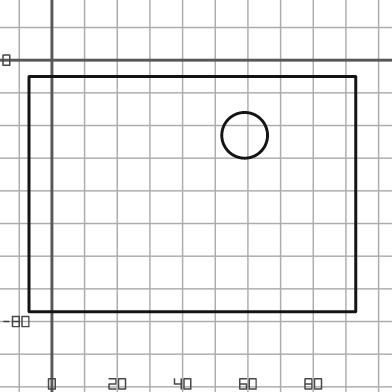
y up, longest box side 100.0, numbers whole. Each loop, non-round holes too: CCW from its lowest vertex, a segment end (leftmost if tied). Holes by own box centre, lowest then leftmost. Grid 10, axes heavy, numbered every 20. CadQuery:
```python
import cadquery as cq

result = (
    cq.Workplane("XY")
    .moveTo(-7.0, -77.0)
    .lineTo(93.0, -77.0)
    .lineTo(93.0, -5.0)
    .lineTo(-7.0, -5.0)
    .close()
    .moveTo(59.0, -23.0)
    .circle(7.0)
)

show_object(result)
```